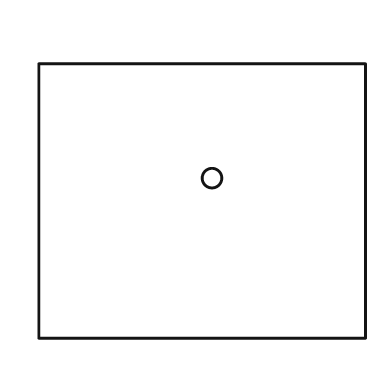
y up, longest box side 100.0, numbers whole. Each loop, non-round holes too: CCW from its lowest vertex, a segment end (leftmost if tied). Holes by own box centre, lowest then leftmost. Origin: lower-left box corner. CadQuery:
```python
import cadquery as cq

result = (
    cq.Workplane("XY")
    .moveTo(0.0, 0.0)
    .lineTo(100.0, 0.0)
    .lineTo(100.0, 84.0)
    .lineTo(0.0, 84.0)
    .close()
    .moveTo(53.0, 49.0)
    .circle(3.0)
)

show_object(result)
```